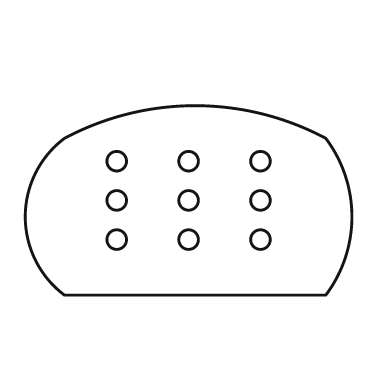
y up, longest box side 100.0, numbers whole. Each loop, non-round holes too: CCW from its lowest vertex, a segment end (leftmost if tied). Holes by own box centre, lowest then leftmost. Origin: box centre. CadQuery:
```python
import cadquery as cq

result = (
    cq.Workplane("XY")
    .moveTo(-38.0, -29.0)
    .lineTo(42.0, -29.0)
    .threePointArc((50.0, -5.0), (42.0, 19.0))
    .threePointArc((2.0, 29.0), (-38.0, 19.0))
    .threePointArc((-50.0, -5.0), (-38.0, -29.0))
    .close()
    .moveTo(-22.0, -12.0)
    .circle(3.0)
    .moveTo(0.0, -12.0)
    .circle(3.0)
    .moveTo(22.0, -12.0)
    .circle(3.0)
    .moveTo(-22.0, 0.0)
    .circle(3.0)
    .moveTo(0.0, 0.0)
    .circle(3.0)
    .moveTo(22.0, 0.0)
    .circle(3.0)
    .moveTo(-22.0, 12.0)
    .circle(3.0)
    .moveTo(0.0, 12.0)
    .circle(3.0)
    .moveTo(22.0, 12.0)
    .circle(3.0)
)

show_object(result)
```